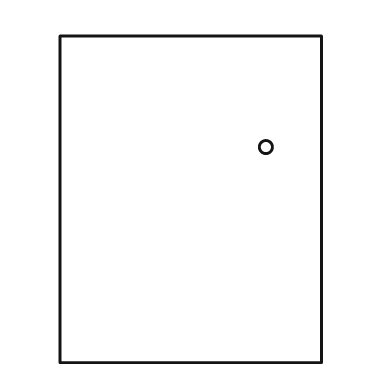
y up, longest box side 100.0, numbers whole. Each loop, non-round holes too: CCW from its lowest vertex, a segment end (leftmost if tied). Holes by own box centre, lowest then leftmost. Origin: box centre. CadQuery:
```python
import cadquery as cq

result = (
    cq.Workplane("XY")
    .moveTo(-40.0, -50.0)
    .lineTo(40.0, -50.0)
    .lineTo(40.0, 50.0)
    .lineTo(-40.0, 50.0)
    .close()
    .moveTo(23.0, 16.0)
    .circle(2.0)
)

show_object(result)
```